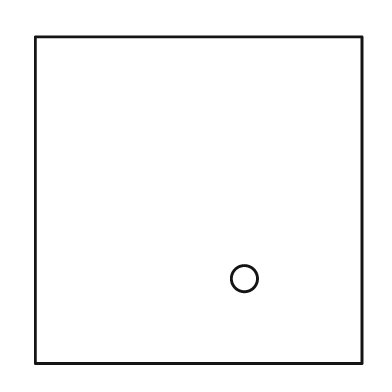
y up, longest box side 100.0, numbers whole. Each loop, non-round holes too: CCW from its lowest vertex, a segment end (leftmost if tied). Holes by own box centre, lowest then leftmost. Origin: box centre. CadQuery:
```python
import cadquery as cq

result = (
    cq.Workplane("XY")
    .moveTo(-50.0, -50.0)
    .lineTo(50.0, -50.0)
    .lineTo(50.0, 50.0)
    .lineTo(-50.0, 50.0)
    .close()
    .moveTo(14.0, -24.0)
    .circle(4.0)
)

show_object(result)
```